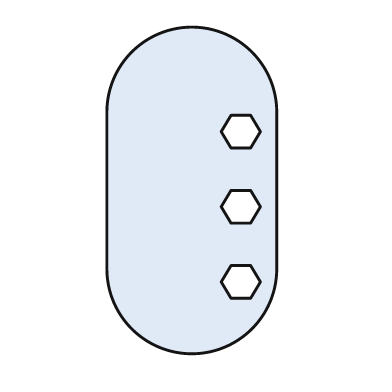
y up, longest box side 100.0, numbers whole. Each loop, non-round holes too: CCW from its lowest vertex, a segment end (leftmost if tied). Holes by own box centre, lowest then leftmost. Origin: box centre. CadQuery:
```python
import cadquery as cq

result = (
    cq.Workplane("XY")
    .moveTo(-26.0, -24.0)
    .threePointArc((0.0, -50.0), (26.0, -24.0))
    .lineTo(26.0, 24.0)
    .threePointArc((0.0, 50.0), (-26.0, 24.0))
    .close()
    .moveTo(12.0, -33.0)
    .lineTo(18.0, -33.0)
    .lineTo(21.0, -28.0)
    .lineTo(18.0, -23.0)
    .lineTo(12.0, -23.0)
    .lineTo(9.0, -28.0)
    .close()
    .moveTo(12.0, -10.0)
    .lineTo(18.0, -10.0)
    .lineTo(21.0, -5.0)
    .lineTo(18.0, 0.0)
    .lineTo(12.0, 0.0)
    .lineTo(9.0, -5.0)
    .close()
    .moveTo(12.0, 13.0)
    .lineTo(18.0, 13.0)
    .lineTo(21.0, 18.0)
    .lineTo(18.0, 23.0)
    .lineTo(12.0, 23.0)
    .lineTo(9.0, 18.0)
    .close()
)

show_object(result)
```